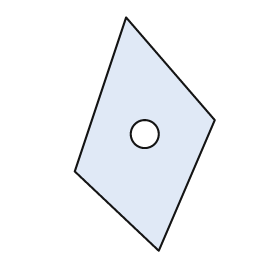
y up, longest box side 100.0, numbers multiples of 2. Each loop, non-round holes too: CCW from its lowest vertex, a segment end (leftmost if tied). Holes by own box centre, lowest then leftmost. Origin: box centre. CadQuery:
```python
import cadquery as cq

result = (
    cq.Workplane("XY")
    .moveTo(6.0, -50.0)
    .lineTo(30.0, 6.0)
    .lineTo(-8.0, 50.0)
    .lineTo(-30.0, -16.0)
    .close()
    .moveTo(0.0, 0.0)
    .circle(6.0)
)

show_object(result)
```